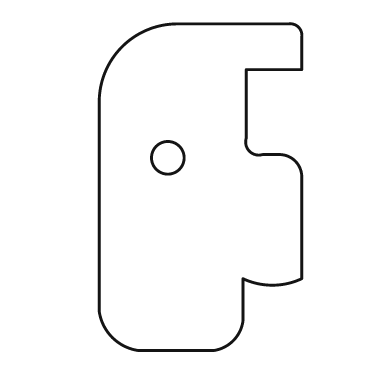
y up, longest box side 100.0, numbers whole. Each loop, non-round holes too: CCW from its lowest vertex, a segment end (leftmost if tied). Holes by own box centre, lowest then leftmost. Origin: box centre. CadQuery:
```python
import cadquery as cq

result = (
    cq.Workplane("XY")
    .moveTo(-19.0, -50.0)
    .lineTo(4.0, -50.0)
    .threePointArc((10.0, -47.0), (13.0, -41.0))
    .lineTo(13.0, -28.0)
    .threePointArc((22.0, -30.0), (31.0, -28.0))
    .lineTo(31.0, 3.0)
    .threePointArc((29.0, 8.0), (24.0, 10.0))
    .lineTo(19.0, 10.0)
    .threePointArc((15.0, 11.0), (14.0, 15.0))
    .lineTo(14.0, 36.0)
    .lineTo(31.0, 36.0)
    .lineTo(31.0, 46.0)
    .threePointArc((30.0, 49.0), (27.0, 50.0))
    .lineTo(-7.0, 50.0)
    .threePointArc((-24.0, 43.0), (-31.0, 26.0))
    .lineTo(-31.0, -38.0)
    .threePointArc((-27.0, -46.0), (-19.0, -50.0))
    .close()
    .moveTo(-10.0, 9.0)
    .circle(5.0)
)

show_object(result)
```